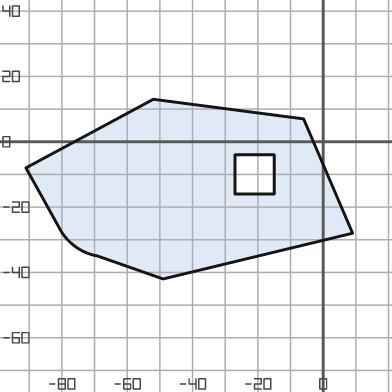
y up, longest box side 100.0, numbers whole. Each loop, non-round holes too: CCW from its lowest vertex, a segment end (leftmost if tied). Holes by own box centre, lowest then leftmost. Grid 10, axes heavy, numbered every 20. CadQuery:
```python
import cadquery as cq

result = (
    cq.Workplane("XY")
    .moveTo(-49.0, -42.0)
    .lineTo(9.0, -28.0)
    .lineTo(-6.0, 7.0)
    .lineTo(-52.0, 13.0)
    .lineTo(-91.0, -8.0)
    .lineTo(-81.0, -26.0)
    .threePointArc((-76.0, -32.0), (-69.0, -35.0))
    .close()
    .moveTo(-27.0, -16.0)
    .lineTo(-15.0, -16.0)
    .lineTo(-15.0, -4.0)
    .lineTo(-27.0, -4.0)
    .close()
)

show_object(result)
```